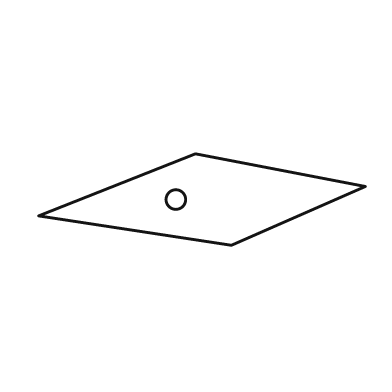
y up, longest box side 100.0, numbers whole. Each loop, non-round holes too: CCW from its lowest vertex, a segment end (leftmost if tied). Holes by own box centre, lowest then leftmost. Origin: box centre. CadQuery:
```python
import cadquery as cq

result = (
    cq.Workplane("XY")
    .moveTo(9.0, -14.0)
    .lineTo(50.0, 4.0)
    .lineTo(-2.0, 14.0)
    .lineTo(-50.0, -5.0)
    .close()
    .moveTo(-8.0, 0.0)
    .circle(3.0)
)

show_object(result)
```